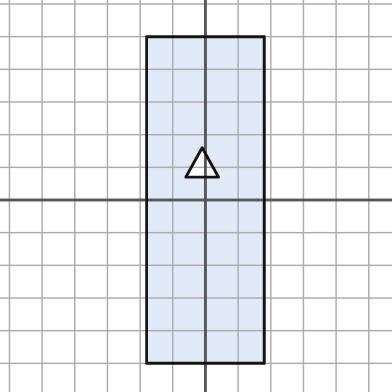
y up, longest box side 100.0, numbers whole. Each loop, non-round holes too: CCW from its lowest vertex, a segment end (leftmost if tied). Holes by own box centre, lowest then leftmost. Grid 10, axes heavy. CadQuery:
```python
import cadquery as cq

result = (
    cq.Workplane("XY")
    .moveTo(-18.0, -50.0)
    .lineTo(18.0, -50.0)
    .lineTo(18.0, 50.0)
    .lineTo(-18.0, 50.0)
    .close()
    .moveTo(-6.0, 7.0)
    .lineTo(4.0, 7.0)
    .lineTo(-1.0, 16.0)
    .close()
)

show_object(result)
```